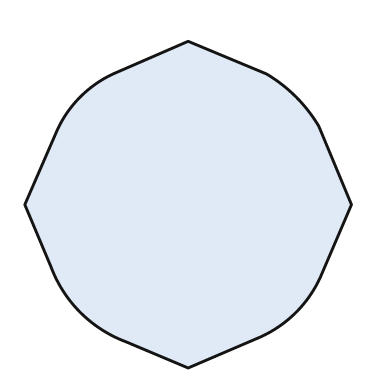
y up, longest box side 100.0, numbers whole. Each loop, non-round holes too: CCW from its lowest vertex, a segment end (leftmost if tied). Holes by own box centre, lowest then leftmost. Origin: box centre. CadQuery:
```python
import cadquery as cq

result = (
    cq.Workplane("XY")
    .moveTo(0.0, -50.0)
    .lineTo(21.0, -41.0)
    .threePointArc((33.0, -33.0), (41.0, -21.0))
    .lineTo(50.0, 0.0)
    .lineTo(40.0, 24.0)
    .threePointArc((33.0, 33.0), (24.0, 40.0))
    .lineTo(0.0, 50.0)
    .lineTo(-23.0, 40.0)
    .threePointArc((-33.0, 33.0), (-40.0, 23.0))
    .lineTo(-50.0, 0.0)
    .lineTo(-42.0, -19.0)
    .threePointArc((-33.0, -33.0), (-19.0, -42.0))
    .close()
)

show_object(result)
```